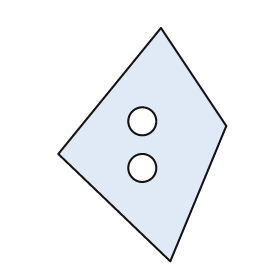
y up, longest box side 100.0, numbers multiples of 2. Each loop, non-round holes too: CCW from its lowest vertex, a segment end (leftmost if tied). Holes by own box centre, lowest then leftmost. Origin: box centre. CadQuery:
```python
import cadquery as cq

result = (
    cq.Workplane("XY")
    .moveTo(12.0, -50.0)
    .lineTo(36.0, 8.0)
    .lineTo(8.0, 50.0)
    .lineTo(-36.0, -4.0)
    .close()
    .moveTo(0.0, -10.0)
    .circle(6.0)
    .moveTo(0.0, 10.0)
    .circle(6.0)
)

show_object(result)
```